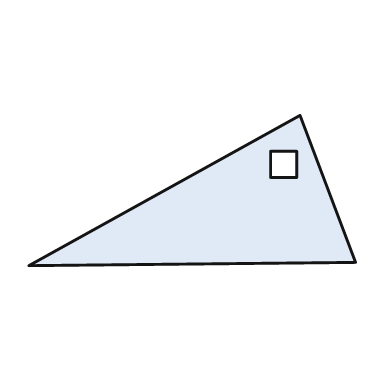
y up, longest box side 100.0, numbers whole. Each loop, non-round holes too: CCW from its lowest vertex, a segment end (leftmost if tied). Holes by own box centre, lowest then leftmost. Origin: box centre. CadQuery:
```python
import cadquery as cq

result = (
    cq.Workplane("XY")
    .moveTo(-50.0, -23.0)
    .lineTo(50.0, -22.0)
    .lineTo(33.0, 23.0)
    .close()
    .moveTo(24.0, 4.0)
    .lineTo(32.0, 4.0)
    .lineTo(32.0, 12.0)
    .lineTo(24.0, 12.0)
    .close()
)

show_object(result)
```